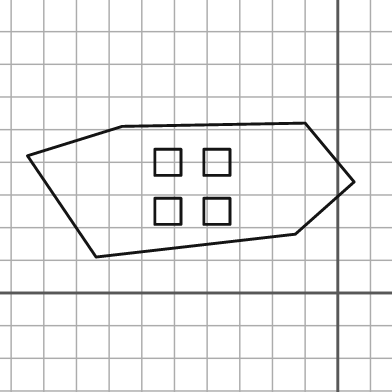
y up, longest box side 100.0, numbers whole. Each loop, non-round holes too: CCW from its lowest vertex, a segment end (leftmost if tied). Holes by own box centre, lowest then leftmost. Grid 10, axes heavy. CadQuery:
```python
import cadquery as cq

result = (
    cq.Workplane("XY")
    .moveTo(-74.0, 11.0)
    .lineTo(-13.0, 18.0)
    .lineTo(5.0, 34.0)
    .lineTo(-10.0, 52.0)
    .lineTo(-66.0, 51.0)
    .lineTo(-95.0, 42.0)
    .close()
    .moveTo(-56.0, 21.0)
    .lineTo(-48.0, 21.0)
    .lineTo(-48.0, 29.0)
    .lineTo(-56.0, 29.0)
    .close()
    .moveTo(-41.0, 21.0)
    .lineTo(-33.0, 21.0)
    .lineTo(-33.0, 29.0)
    .lineTo(-41.0, 29.0)
    .close()
    .moveTo(-56.0, 36.0)
    .lineTo(-48.0, 36.0)
    .lineTo(-48.0, 44.0)
    .lineTo(-56.0, 44.0)
    .close()
    .moveTo(-41.0, 36.0)
    .lineTo(-33.0, 36.0)
    .lineTo(-33.0, 44.0)
    .lineTo(-41.0, 44.0)
    .close()
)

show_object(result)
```